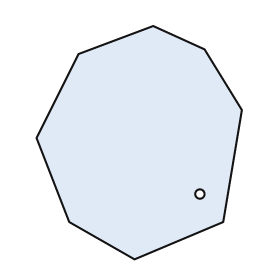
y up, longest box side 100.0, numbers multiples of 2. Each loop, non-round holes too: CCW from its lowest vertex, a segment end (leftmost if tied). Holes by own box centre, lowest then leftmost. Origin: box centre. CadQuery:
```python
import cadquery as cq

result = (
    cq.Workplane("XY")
    .moveTo(-2.0, -50.0)
    .lineTo(36.0, -34.0)
    .lineTo(44.0, 14.0)
    .lineTo(28.0, 40.0)
    .lineTo(6.0, 50.0)
    .lineTo(-26.0, 38.0)
    .lineTo(-44.0, 2.0)
    .lineTo(-30.0, -34.0)
    .close()
    .moveTo(26.0, -22.0)
    .circle(2.0)
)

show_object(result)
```